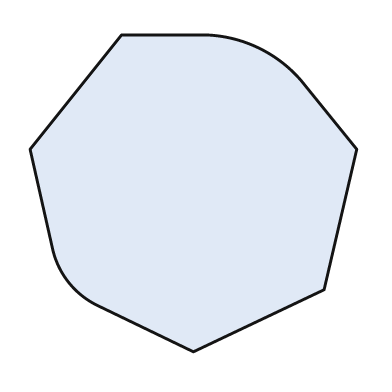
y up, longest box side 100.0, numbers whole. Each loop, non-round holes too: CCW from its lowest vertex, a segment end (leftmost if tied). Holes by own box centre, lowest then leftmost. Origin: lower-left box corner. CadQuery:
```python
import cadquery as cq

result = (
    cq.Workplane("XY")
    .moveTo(50.0, 0.0)
    .lineTo(90.0, 19.0)
    .lineTo(100.0, 62.0)
    .lineTo(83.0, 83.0)
    .threePointArc((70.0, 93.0), (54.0, 97.0))
    .lineTo(28.0, 97.0)
    .lineTo(0.0, 62.0)
    .lineTo(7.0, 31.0)
    .threePointArc((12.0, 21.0), (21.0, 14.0))
    .close()
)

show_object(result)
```